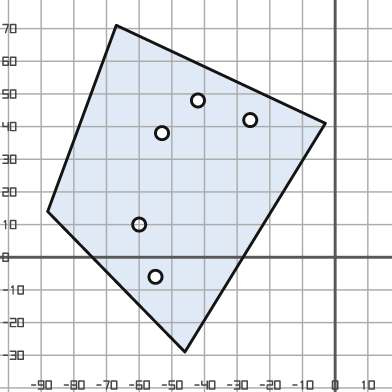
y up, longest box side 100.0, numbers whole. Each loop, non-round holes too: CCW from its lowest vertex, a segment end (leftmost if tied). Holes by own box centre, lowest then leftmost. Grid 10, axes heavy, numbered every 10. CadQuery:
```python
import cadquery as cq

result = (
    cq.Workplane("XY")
    .moveTo(-46.0, -29.0)
    .lineTo(-3.0, 41.0)
    .lineTo(-67.0, 71.0)
    .lineTo(-88.0, 14.0)
    .close()
    .moveTo(-55.0, -6.0)
    .circle(2.0)
    .moveTo(-60.0, 10.0)
    .circle(2.0)
    .moveTo(-53.0, 38.0)
    .circle(2.0)
    .moveTo(-26.0, 42.0)
    .circle(2.0)
    .moveTo(-42.0, 48.0)
    .circle(2.0)
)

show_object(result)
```